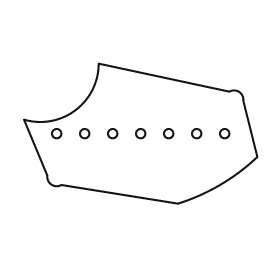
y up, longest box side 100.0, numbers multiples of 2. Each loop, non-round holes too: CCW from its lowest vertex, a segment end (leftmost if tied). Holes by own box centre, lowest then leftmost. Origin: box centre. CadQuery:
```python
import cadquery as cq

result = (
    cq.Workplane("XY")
    .moveTo(16.0, -30.0)
    .threePointArc((34.0, -22.0), (50.0, -10.0))
    .lineTo(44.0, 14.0)
    .threePointArc((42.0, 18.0), (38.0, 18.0))
    .lineTo(-18.0, 30.0)
    .threePointArc((-28.0, 10.0), (-50.0, 6.0))
    .lineTo(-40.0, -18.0)
    .threePointArc((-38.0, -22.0), (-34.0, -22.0))
    .close()
    .moveTo(-36.0, 0.0)
    .circle(2.0)
    .moveTo(-24.0, 0.0)
    .circle(2.0)
    .moveTo(-12.0, 0.0)
    .circle(2.0)
    .moveTo(0.0, 0.0)
    .circle(2.0)
    .moveTo(12.0, 0.0)
    .circle(2.0)
    .moveTo(24.0, 0.0)
    .circle(2.0)
    .moveTo(36.0, 0.0)
    .circle(2.0)
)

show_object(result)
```